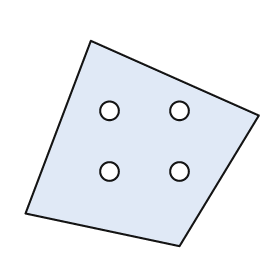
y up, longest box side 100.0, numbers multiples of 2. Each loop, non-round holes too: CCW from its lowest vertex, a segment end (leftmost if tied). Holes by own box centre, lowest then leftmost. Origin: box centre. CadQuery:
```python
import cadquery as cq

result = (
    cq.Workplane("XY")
    .moveTo(16.0, -44.0)
    .lineTo(50.0, 12.0)
    .lineTo(-22.0, 44.0)
    .lineTo(-50.0, -30.0)
    .close()
    .moveTo(-14.0, -12.0)
    .circle(4.0)
    .moveTo(16.0, -12.0)
    .circle(4.0)
    .moveTo(-14.0, 14.0)
    .circle(4.0)
    .moveTo(16.0, 14.0)
    .circle(4.0)
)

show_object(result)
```